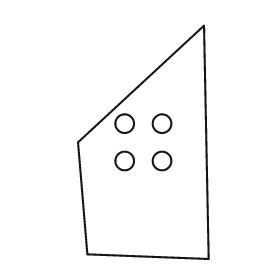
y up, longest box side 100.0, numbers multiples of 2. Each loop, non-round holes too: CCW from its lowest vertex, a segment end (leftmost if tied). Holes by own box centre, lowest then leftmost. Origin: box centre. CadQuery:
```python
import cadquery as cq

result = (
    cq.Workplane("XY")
    .moveTo(28.0, -50.0)
    .lineTo(26.0, 50.0)
    .lineTo(-28.0, 0.0)
    .lineTo(-24.0, -48.0)
    .close()
    .moveTo(-8.0, -8.0)
    .circle(4.0)
    .moveTo(8.0, -8.0)
    .circle(4.0)
    .moveTo(-8.0, 8.0)
    .circle(4.0)
    .moveTo(8.0, 8.0)
    .circle(4.0)
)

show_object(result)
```